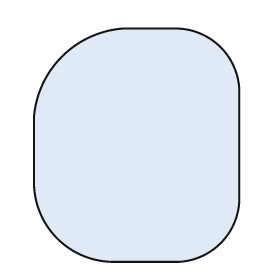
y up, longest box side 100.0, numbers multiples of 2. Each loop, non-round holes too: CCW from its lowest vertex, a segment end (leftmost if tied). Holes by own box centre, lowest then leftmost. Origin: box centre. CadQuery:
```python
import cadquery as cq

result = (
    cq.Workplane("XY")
    .moveTo(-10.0, -50.0)
    .lineTo(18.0, -50.0)
    .threePointArc((36.0, -42.0), (44.0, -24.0))
    .lineTo(44.0, 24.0)
    .threePointArc((36.0, 42.0), (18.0, 50.0))
    .lineTo(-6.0, 50.0)
    .threePointArc((-32.0, 38.0), (-44.0, 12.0))
    .lineTo(-44.0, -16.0)
    .threePointArc((-34.0, -40.0), (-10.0, -50.0))
    .close()
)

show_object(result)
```